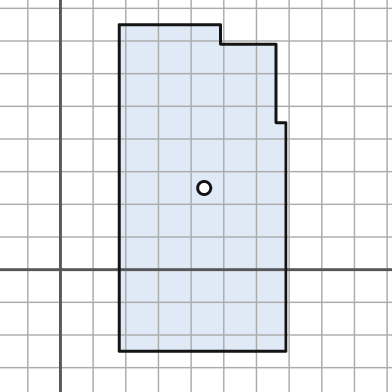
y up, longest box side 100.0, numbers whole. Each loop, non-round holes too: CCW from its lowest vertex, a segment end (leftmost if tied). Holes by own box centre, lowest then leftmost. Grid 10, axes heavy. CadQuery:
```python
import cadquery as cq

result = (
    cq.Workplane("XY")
    .moveTo(18.0, -25.0)
    .lineTo(69.0, -25.0)
    .lineTo(69.0, 45.0)
    .lineTo(66.0, 45.0)
    .lineTo(66.0, 69.0)
    .lineTo(49.0, 69.0)
    .lineTo(49.0, 75.0)
    .lineTo(18.0, 75.0)
    .close()
    .moveTo(44.0, 25.0)
    .circle(2.0)
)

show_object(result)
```